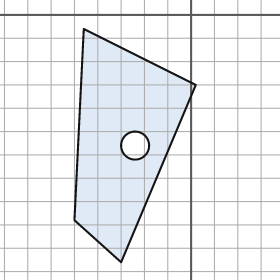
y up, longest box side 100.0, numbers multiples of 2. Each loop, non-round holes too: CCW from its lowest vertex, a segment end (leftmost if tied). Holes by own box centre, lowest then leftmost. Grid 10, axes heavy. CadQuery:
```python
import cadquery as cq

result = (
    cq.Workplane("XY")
    .moveTo(-30.0, -106.0)
    .lineTo(2.0, -30.0)
    .lineTo(-46.0, -6.0)
    .lineTo(-50.0, -88.0)
    .close()
    .moveTo(-24.0, -56.0)
    .circle(6.0)
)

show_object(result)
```